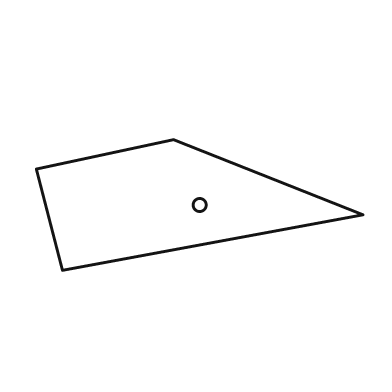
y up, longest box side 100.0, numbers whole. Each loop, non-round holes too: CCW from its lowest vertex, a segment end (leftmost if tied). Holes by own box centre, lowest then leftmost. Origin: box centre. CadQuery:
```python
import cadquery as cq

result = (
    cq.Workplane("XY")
    .moveTo(-42.0, -20.0)
    .lineTo(50.0, -3.0)
    .lineTo(-8.0, 20.0)
    .lineTo(-50.0, 11.0)
    .close()
    .moveTo(0.0, 0.0)
    .circle(2.0)
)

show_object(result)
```